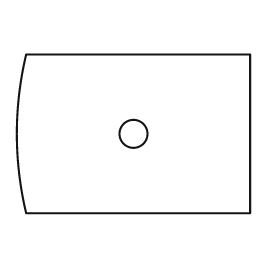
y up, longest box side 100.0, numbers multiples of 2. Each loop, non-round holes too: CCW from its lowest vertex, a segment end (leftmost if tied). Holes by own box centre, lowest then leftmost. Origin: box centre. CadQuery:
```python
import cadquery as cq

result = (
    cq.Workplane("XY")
    .moveTo(-46.0, -34.0)
    .lineTo(50.0, -34.0)
    .lineTo(50.0, 34.0)
    .lineTo(-46.0, 34.0)
    .threePointArc((-50.0, 0.0), (-46.0, -34.0))
    .close()
    .moveTo(0.0, 0.0)
    .circle(6.0)
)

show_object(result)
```